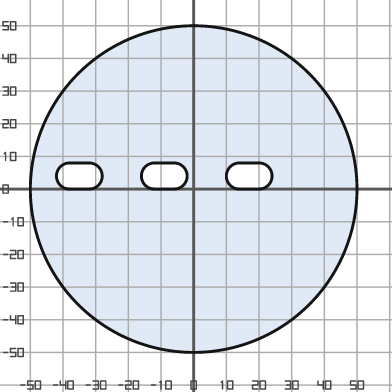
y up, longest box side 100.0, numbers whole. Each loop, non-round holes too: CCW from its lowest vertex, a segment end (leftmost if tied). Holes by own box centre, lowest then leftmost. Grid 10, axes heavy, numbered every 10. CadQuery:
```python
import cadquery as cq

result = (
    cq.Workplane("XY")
    .moveTo(0.0, 0.0)
    .circle(50.0)
    .moveTo(-38.0, 0.0)
    .lineTo(-32.0, 0.0)
    .threePointArc((-28.0, 4.0), (-32.0, 8.0))
    .lineTo(-38.0, 8.0)
    .threePointArc((-42.0, 4.0), (-38.0, 0.0))
    .close()
    .moveTo(-12.0, 0.0)
    .lineTo(-6.0, 0.0)
    .threePointArc((-2.0, 4.0), (-6.0, 8.0))
    .lineTo(-12.0, 8.0)
    .threePointArc((-16.0, 4.0), (-12.0, 0.0))
    .close()
    .moveTo(14.0, 0.0)
    .lineTo(20.0, 0.0)
    .threePointArc((24.0, 4.0), (20.0, 8.0))
    .lineTo(14.0, 8.0)
    .threePointArc((10.0, 4.0), (14.0, 0.0))
    .close()
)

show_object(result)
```